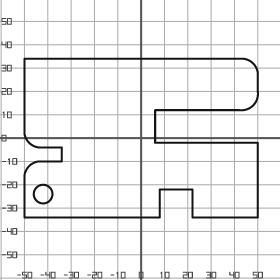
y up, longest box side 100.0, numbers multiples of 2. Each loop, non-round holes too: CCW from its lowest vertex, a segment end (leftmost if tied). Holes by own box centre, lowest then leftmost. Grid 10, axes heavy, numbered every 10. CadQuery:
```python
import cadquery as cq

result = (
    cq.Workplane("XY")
    .moveTo(-50.0, -34.0)
    .lineTo(8.0, -34.0)
    .lineTo(8.0, -22.0)
    .lineTo(22.0, -22.0)
    .lineTo(22.0, -34.0)
    .lineTo(50.0, -34.0)
    .lineTo(50.0, -2.0)
    .lineTo(6.0, -2.0)
    .lineTo(6.0, 12.0)
    .lineTo(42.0, 12.0)
    .threePointArc((48.0, 14.0), (50.0, 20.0))
    .lineTo(50.0, 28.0)
    .threePointArc((48.0, 32.0), (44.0, 34.0))
    .lineTo(-50.0, 34.0)
    .lineTo(-50.0, 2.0)
    .threePointArc((-48.0, -2.0), (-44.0, -4.0))
    .lineTo(-34.0, -4.0)
    .lineTo(-34.0, -10.0)
    .lineTo(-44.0, -10.0)
    .threePointArc((-48.0, -12.0), (-50.0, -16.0))
    .close()
    .moveTo(-42.0, -24.0)
    .circle(4.0)
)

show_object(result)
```